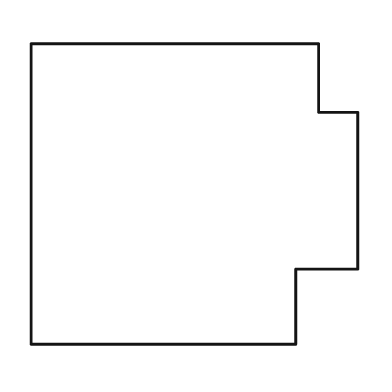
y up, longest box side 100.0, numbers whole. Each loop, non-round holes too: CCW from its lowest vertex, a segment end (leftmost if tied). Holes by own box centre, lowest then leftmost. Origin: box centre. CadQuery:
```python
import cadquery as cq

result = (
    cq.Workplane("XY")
    .moveTo(-50.0, -46.0)
    .lineTo(31.0, -46.0)
    .lineTo(31.0, -23.0)
    .lineTo(50.0, -23.0)
    .lineTo(50.0, 25.0)
    .lineTo(38.0, 25.0)
    .lineTo(38.0, 46.0)
    .lineTo(-50.0, 46.0)
    .close()
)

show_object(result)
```